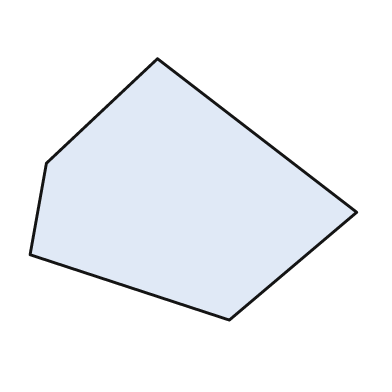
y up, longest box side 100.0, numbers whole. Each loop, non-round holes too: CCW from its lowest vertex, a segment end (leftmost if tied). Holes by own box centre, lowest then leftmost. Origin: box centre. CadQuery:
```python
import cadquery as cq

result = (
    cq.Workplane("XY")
    .moveTo(11.0, -40.0)
    .lineTo(50.0, -7.0)
    .lineTo(-11.0, 40.0)
    .lineTo(-45.0, 8.0)
    .lineTo(-50.0, -20.0)
    .close()
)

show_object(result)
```